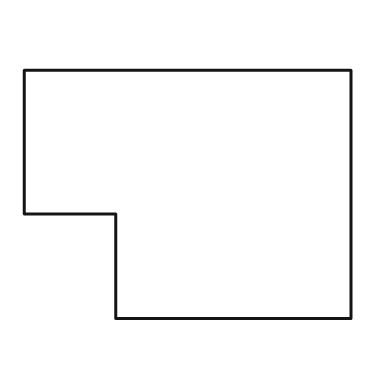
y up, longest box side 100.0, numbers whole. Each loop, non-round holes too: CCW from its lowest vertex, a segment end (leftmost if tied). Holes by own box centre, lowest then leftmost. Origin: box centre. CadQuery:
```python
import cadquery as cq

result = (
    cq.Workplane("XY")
    .moveTo(-22.0, -38.0)
    .lineTo(50.0, -38.0)
    .lineTo(50.0, 38.0)
    .lineTo(-50.0, 38.0)
    .lineTo(-50.0, -6.0)
    .lineTo(-22.0, -6.0)
    .close()
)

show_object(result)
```